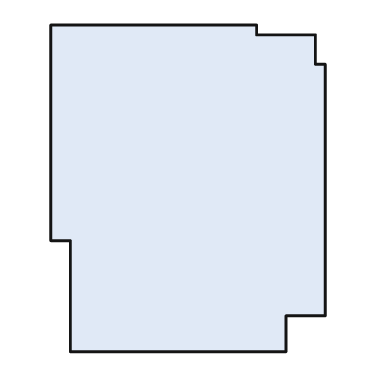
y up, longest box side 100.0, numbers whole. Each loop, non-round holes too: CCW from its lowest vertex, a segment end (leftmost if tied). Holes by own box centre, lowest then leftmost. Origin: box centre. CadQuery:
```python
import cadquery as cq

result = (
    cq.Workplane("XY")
    .moveTo(-36.0, -50.0)
    .lineTo(30.0, -50.0)
    .lineTo(30.0, -39.0)
    .lineTo(42.0, -39.0)
    .lineTo(42.0, 38.0)
    .lineTo(39.0, 38.0)
    .lineTo(39.0, 47.0)
    .lineTo(21.0, 47.0)
    .lineTo(21.0, 50.0)
    .lineTo(-42.0, 50.0)
    .lineTo(-42.0, -16.0)
    .lineTo(-36.0, -16.0)
    .close()
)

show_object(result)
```